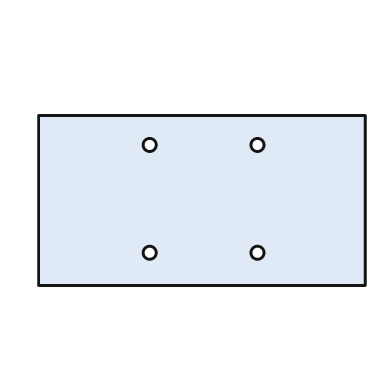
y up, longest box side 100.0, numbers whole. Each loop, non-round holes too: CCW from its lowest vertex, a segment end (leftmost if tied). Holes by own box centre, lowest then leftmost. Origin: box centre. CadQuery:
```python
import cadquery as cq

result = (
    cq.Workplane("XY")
    .moveTo(-50.0, -26.0)
    .lineTo(50.0, -26.0)
    .lineTo(50.0, 26.0)
    .lineTo(-50.0, 26.0)
    .close()
    .moveTo(-16.0, -16.0)
    .circle(2.0)
    .moveTo(17.0, -16.0)
    .circle(2.0)
    .moveTo(-16.0, 17.0)
    .circle(2.0)
    .moveTo(17.0, 17.0)
    .circle(2.0)
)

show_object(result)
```